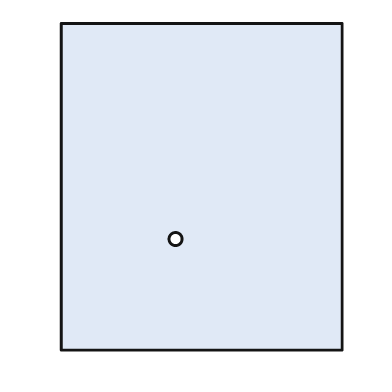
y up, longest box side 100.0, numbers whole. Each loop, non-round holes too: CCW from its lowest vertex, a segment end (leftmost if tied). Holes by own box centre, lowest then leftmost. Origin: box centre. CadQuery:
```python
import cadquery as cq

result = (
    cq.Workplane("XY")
    .moveTo(-43.0, -50.0)
    .lineTo(43.0, -50.0)
    .lineTo(43.0, 50.0)
    .lineTo(-43.0, 50.0)
    .close()
    .moveTo(-8.0, -16.0)
    .circle(2.0)
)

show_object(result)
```